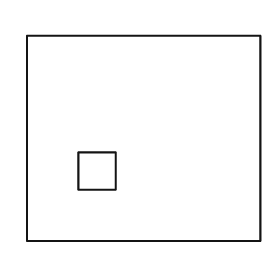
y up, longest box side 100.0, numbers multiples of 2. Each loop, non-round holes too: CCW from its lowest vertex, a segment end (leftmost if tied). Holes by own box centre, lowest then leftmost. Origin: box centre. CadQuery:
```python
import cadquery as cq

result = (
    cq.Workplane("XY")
    .moveTo(-50.0, -44.0)
    .lineTo(50.0, -44.0)
    .lineTo(50.0, 44.0)
    .lineTo(-50.0, 44.0)
    .close()
    .moveTo(-28.0, -22.0)
    .lineTo(-12.0, -22.0)
    .lineTo(-12.0, -6.0)
    .lineTo(-28.0, -6.0)
    .close()
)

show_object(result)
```